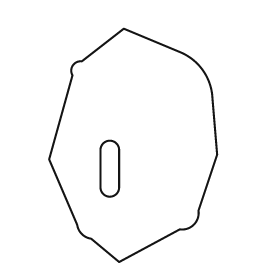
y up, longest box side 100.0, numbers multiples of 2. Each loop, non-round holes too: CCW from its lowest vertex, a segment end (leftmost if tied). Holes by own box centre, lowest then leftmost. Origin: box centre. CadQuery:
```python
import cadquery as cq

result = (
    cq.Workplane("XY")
    .moveTo(-6.0, -50.0)
    .lineTo(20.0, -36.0)
    .threePointArc((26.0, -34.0), (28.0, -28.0))
    .lineTo(36.0, -4.0)
    .lineTo(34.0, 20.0)
    .threePointArc((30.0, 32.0), (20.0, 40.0))
    .lineTo(-4.0, 50.0)
    .lineTo(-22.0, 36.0)
    .threePointArc((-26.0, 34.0), (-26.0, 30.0))
    .lineTo(-36.0, -6.0)
    .lineTo(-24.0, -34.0)
    .threePointArc((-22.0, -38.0), (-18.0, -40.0))
    .close()
    .moveTo(-14.0, -18.0)
    .threePointArc((-10.0, -22.0), (-6.0, -18.0))
    .lineTo(-6.0, -2.0)
    .threePointArc((-10.0, 2.0), (-14.0, -2.0))
    .close()
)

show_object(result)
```